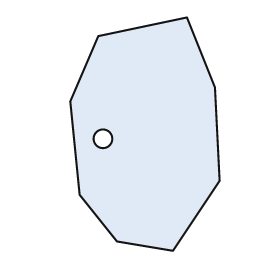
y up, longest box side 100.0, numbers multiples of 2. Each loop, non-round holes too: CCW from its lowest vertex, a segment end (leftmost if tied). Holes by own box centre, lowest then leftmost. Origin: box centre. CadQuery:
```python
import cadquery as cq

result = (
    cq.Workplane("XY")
    .moveTo(12.0, -50.0)
    .lineTo(32.0, -20.0)
    .lineTo(30.0, 20.0)
    .lineTo(18.0, 50.0)
    .lineTo(-20.0, 42.0)
    .lineTo(-32.0, 14.0)
    .lineTo(-28.0, -26.0)
    .lineTo(-12.0, -46.0)
    .close()
    .moveTo(-18.0, -2.0)
    .circle(4.0)
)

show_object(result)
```